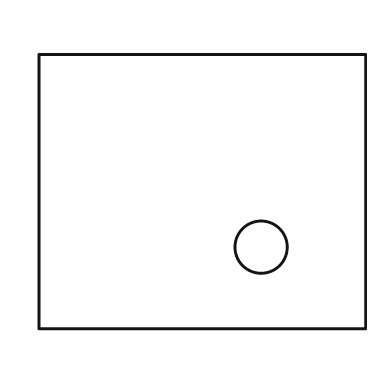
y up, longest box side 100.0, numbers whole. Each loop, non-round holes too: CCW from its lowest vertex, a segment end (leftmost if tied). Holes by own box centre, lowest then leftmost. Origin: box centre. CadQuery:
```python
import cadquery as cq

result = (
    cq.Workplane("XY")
    .moveTo(-50.0, -42.0)
    .lineTo(50.0, -42.0)
    .lineTo(50.0, 42.0)
    .lineTo(-50.0, 42.0)
    .close()
    .moveTo(18.0, -17.0)
    .circle(8.0)
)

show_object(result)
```